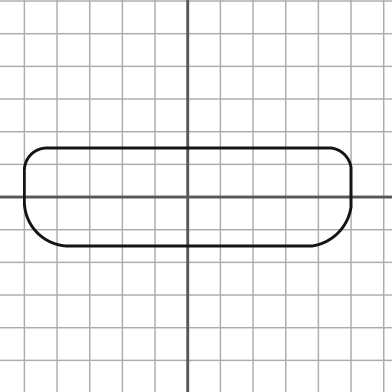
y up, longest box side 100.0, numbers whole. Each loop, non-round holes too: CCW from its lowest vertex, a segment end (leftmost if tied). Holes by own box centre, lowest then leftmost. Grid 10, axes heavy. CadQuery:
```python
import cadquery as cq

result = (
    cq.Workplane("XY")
    .moveTo(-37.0, -15.0)
    .lineTo(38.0, -15.0)
    .threePointArc((46.0, -11.0), (50.0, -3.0))
    .lineTo(50.0, 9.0)
    .threePointArc((48.0, 13.0), (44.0, 15.0))
    .lineTo(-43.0, 15.0)
    .threePointArc((-48.0, 13.0), (-50.0, 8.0))
    .lineTo(-50.0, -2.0)
    .threePointArc((-46.0, -11.0), (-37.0, -15.0))
    .close()
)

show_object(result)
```